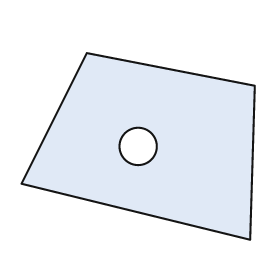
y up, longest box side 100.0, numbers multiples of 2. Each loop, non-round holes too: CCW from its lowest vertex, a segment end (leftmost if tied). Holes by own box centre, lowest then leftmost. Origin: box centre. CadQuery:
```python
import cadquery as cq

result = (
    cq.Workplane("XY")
    .moveTo(48.0, -40.0)
    .lineTo(50.0, 26.0)
    .lineTo(-22.0, 40.0)
    .lineTo(-50.0, -16.0)
    .close()
    .moveTo(0.0, 0.0)
    .circle(8.0)
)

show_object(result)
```